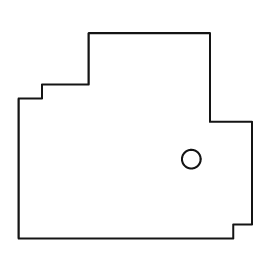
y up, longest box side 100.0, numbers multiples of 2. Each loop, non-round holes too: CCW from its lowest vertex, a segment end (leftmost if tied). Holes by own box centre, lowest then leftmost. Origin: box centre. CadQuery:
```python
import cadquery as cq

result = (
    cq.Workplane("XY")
    .moveTo(-50.0, -44.0)
    .lineTo(42.0, -44.0)
    .lineTo(42.0, -38.0)
    .lineTo(50.0, -38.0)
    .lineTo(50.0, 6.0)
    .lineTo(32.0, 6.0)
    .lineTo(32.0, 44.0)
    .lineTo(-20.0, 44.0)
    .lineTo(-20.0, 22.0)
    .lineTo(-40.0, 22.0)
    .lineTo(-40.0, 16.0)
    .lineTo(-50.0, 16.0)
    .close()
    .moveTo(24.0, -10.0)
    .circle(4.0)
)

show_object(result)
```